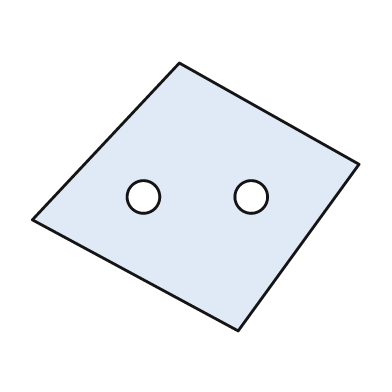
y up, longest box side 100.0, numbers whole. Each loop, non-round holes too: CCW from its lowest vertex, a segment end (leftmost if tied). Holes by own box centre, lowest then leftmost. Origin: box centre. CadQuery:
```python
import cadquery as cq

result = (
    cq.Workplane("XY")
    .moveTo(13.0, -41.0)
    .lineTo(50.0, 10.0)
    .lineTo(-5.0, 41.0)
    .lineTo(-50.0, -7.0)
    .close()
    .moveTo(-16.0, 0.0)
    .circle(5.0)
    .moveTo(17.0, 0.0)
    .circle(5.0)
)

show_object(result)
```